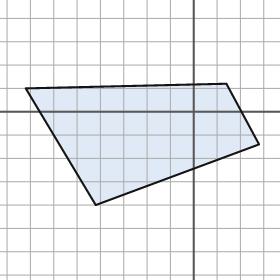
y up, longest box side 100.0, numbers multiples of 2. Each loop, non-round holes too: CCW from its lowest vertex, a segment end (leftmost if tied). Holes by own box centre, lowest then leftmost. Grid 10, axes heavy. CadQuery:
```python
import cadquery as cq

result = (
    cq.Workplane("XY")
    .moveTo(-42.0, -40.0)
    .lineTo(28.0, -14.0)
    .lineTo(14.0, 12.0)
    .lineTo(-72.0, 10.0)
    .close()
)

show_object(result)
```